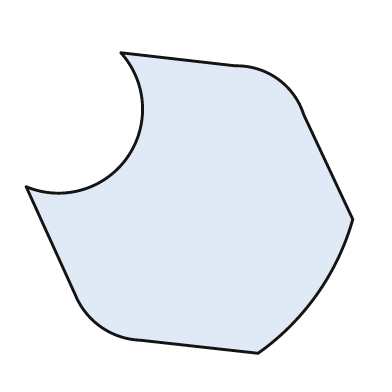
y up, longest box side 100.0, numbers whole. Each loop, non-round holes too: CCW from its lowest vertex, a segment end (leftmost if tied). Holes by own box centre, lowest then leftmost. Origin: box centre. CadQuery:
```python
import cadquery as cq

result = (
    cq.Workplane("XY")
    .moveTo(21.0, -46.0)
    .threePointArc((39.0, -28.0), (50.0, -5.0))
    .lineTo(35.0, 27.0)
    .threePointArc((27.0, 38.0), (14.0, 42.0))
    .lineTo(-21.0, 46.0)
    .threePointArc((-19.0, 14.0), (-50.0, 5.0))
    .lineTo(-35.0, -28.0)
    .threePointArc((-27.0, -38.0), (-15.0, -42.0))
    .close()
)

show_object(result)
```